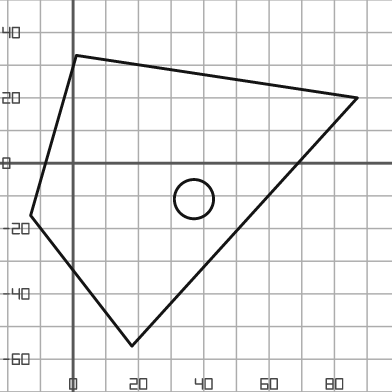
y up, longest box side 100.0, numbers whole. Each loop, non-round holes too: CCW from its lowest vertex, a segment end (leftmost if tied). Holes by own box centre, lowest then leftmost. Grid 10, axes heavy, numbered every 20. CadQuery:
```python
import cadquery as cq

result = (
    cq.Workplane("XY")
    .moveTo(18.0, -56.0)
    .lineTo(87.0, 20.0)
    .lineTo(1.0, 33.0)
    .lineTo(-13.0, -16.0)
    .close()
    .moveTo(37.0, -11.0)
    .circle(6.0)
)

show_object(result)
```